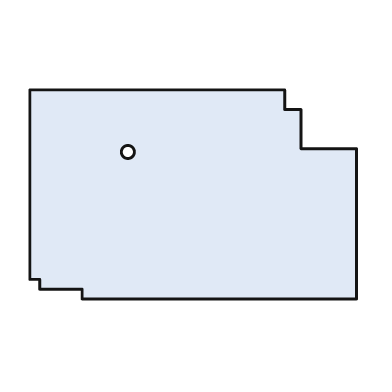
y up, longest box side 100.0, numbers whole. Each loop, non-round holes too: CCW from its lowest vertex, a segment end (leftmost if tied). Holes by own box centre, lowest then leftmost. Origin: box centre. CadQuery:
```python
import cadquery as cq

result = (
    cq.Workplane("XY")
    .moveTo(-34.0, -32.0)
    .lineTo(50.0, -32.0)
    .lineTo(50.0, 14.0)
    .lineTo(33.0, 14.0)
    .lineTo(33.0, 26.0)
    .lineTo(28.0, 26.0)
    .lineTo(28.0, 32.0)
    .lineTo(-50.0, 32.0)
    .lineTo(-50.0, -26.0)
    .lineTo(-47.0, -26.0)
    .lineTo(-47.0, -29.0)
    .lineTo(-34.0, -29.0)
    .close()
    .moveTo(-20.0, 13.0)
    .circle(2.0)
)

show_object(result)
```